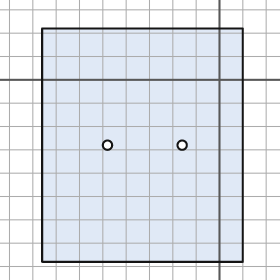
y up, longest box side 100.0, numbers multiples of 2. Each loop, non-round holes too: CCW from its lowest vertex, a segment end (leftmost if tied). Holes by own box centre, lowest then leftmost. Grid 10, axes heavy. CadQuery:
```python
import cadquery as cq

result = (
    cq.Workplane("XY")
    .moveTo(-76.0, -78.0)
    .lineTo(10.0, -78.0)
    .lineTo(10.0, 22.0)
    .lineTo(-76.0, 22.0)
    .close()
    .moveTo(-48.0, -28.0)
    .circle(2.0)
    .moveTo(-16.0, -28.0)
    .circle(2.0)
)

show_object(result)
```